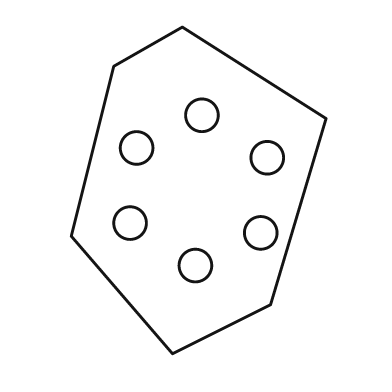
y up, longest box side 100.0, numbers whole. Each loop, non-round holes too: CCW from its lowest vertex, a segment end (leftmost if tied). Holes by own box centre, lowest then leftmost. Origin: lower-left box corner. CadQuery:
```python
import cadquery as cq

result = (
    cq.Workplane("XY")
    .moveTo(31.0, 0.0)
    .lineTo(61.0, 15.0)
    .lineTo(78.0, 72.0)
    .lineTo(34.0, 100.0)
    .lineTo(13.0, 88.0)
    .lineTo(0.0, 36.0)
    .close()
    .moveTo(38.0, 27.0)
    .circle(5.0)
    .moveTo(58.0, 37.0)
    .circle(5.0)
    .moveTo(18.0, 40.0)
    .circle(5.0)
    .moveTo(60.0, 60.0)
    .circle(5.0)
    .moveTo(20.0, 63.0)
    .circle(5.0)
    .moveTo(40.0, 73.0)
    .circle(5.0)
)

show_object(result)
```